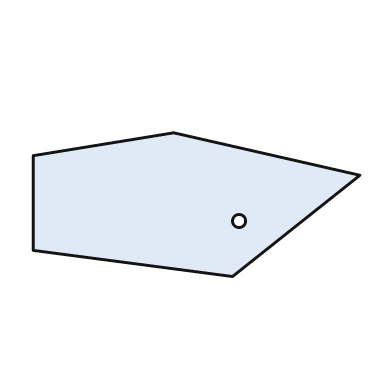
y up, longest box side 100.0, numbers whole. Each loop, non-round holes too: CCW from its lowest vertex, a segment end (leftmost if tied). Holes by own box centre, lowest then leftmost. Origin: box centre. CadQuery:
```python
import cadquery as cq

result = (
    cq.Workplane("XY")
    .moveTo(11.0, -22.0)
    .lineTo(50.0, 9.0)
    .lineTo(-7.0, 22.0)
    .lineTo(-50.0, 15.0)
    .lineTo(-50.0, -14.0)
    .close()
    .moveTo(13.0, -5.0)
    .circle(2.0)
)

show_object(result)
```